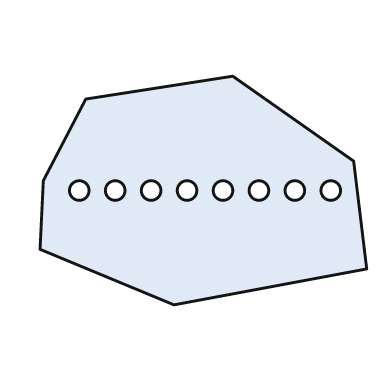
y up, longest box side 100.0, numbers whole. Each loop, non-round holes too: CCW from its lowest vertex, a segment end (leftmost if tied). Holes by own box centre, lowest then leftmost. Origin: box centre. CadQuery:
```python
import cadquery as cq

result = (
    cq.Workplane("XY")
    .moveTo(-9.0, -35.0)
    .lineTo(50.0, -24.0)
    .lineTo(46.0, 9.0)
    .lineTo(9.0, 35.0)
    .lineTo(-36.0, 28.0)
    .lineTo(-49.0, 3.0)
    .lineTo(-50.0, -18.0)
    .close()
    .moveTo(-38.0, 0.0)
    .circle(3.0)
    .moveTo(-27.0, 0.0)
    .circle(3.0)
    .moveTo(-16.0, 0.0)
    .circle(3.0)
    .moveTo(-5.0, 0.0)
    .circle(3.0)
    .moveTo(6.0, 0.0)
    .circle(3.0)
    .moveTo(17.0, 0.0)
    .circle(3.0)
    .moveTo(28.0, 0.0)
    .circle(3.0)
    .moveTo(39.0, 0.0)
    .circle(3.0)
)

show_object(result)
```